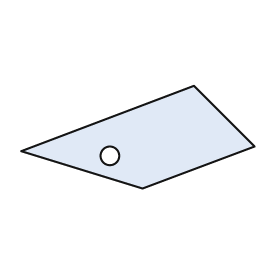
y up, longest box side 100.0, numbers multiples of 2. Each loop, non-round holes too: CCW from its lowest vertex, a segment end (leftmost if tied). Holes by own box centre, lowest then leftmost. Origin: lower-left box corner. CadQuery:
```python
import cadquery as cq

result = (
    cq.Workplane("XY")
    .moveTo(52.0, 0.0)
    .lineTo(100.0, 18.0)
    .lineTo(74.0, 44.0)
    .lineTo(0.0, 16.0)
    .close()
    .moveTo(38.0, 14.0)
    .circle(4.0)
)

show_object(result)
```